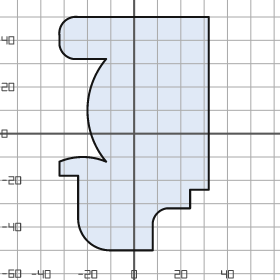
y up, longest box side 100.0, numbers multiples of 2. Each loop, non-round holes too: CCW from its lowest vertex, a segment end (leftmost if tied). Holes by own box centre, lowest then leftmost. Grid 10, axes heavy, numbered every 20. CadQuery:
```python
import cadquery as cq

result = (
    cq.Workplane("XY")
    .moveTo(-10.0, -50.0)
    .lineTo(8.0, -50.0)
    .lineTo(8.0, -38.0)
    .threePointArc((10.0, -34.0), (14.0, -32.0))
    .lineTo(24.0, -32.0)
    .lineTo(24.0, -24.0)
    .lineTo(32.0, -24.0)
    .lineTo(32.0, 50.0)
    .lineTo(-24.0, 50.0)
    .threePointArc((-30.0, 48.0), (-32.0, 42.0))
    .lineTo(-32.0, 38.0)
    .threePointArc((-30.0, 34.0), (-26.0, 32.0))
    .lineTo(-12.0, 32.0)
    .threePointArc((-20.0, 10.0), (-12.0, -12.0))
    .threePointArc((-22.0, -10.0), (-32.0, -12.0))
    .lineTo(-32.0, -18.0)
    .lineTo(-24.0, -18.0)
    .lineTo(-24.0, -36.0)
    .threePointArc((-20.0, -46.0), (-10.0, -50.0))
    .close()
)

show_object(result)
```